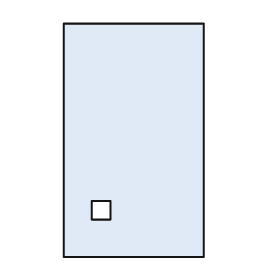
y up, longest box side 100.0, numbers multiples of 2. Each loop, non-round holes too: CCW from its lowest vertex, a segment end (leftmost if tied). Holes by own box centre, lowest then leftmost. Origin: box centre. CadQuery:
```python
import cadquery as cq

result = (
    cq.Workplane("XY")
    .moveTo(-30.0, -50.0)
    .lineTo(30.0, -50.0)
    .lineTo(30.0, 50.0)
    .lineTo(-30.0, 50.0)
    .close()
    .moveTo(-18.0, -34.0)
    .lineTo(-10.0, -34.0)
    .lineTo(-10.0, -26.0)
    .lineTo(-18.0, -26.0)
    .close()
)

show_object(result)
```